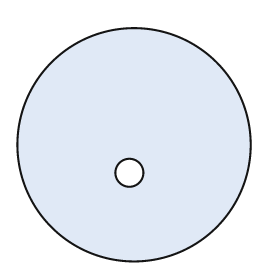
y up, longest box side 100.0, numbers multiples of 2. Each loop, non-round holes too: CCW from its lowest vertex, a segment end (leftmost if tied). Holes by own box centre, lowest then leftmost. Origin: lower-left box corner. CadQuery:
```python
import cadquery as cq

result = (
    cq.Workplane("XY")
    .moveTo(50.0, 50.0)
    .circle(50.0)
    .moveTo(48.0, 38.0)
    .circle(6.0)
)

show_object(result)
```